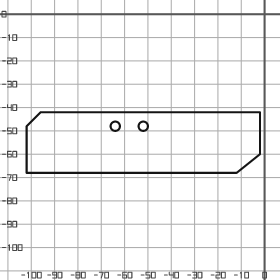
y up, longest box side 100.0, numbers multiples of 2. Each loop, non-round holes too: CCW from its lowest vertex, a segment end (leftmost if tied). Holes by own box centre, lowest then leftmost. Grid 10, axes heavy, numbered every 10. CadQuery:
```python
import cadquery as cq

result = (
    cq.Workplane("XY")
    .moveTo(-102.0, -68.0)
    .lineTo(-12.0, -68.0)
    .lineTo(-2.0, -60.0)
    .lineTo(-2.0, -42.0)
    .lineTo(-96.0, -42.0)
    .lineTo(-102.0, -48.0)
    .close()
    .moveTo(-64.0, -48.0)
    .circle(2.0)
    .moveTo(-52.0, -48.0)
    .circle(2.0)
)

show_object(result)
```